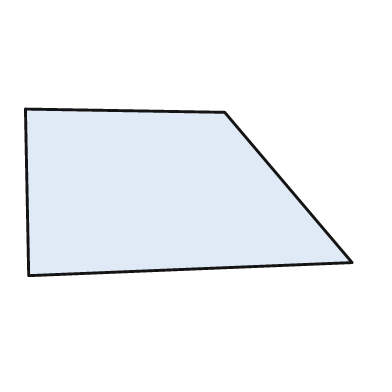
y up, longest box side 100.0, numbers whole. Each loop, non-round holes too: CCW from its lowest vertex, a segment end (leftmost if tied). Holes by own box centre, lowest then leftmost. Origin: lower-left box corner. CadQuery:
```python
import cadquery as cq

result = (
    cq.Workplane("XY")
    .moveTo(1.0, 0.0)
    .lineTo(100.0, 4.0)
    .lineTo(61.0, 50.0)
    .lineTo(0.0, 51.0)
    .close()
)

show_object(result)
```